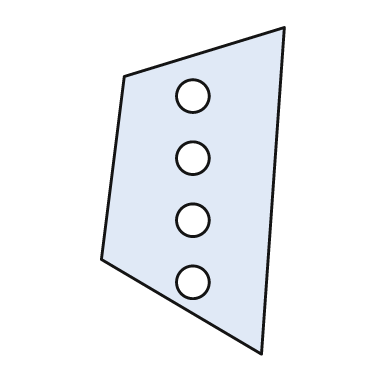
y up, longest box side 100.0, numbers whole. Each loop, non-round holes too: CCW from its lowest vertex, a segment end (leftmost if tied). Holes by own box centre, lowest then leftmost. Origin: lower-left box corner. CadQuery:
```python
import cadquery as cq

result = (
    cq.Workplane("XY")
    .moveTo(49.0, 0.0)
    .lineTo(56.0, 100.0)
    .lineTo(7.0, 85.0)
    .lineTo(0.0, 29.0)
    .close()
    .moveTo(28.0, 22.0)
    .circle(5.0)
    .moveTo(28.0, 41.0)
    .circle(5.0)
    .moveTo(28.0, 60.0)
    .circle(5.0)
    .moveTo(28.0, 79.0)
    .circle(5.0)
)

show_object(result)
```